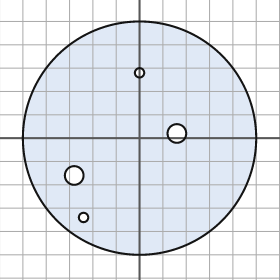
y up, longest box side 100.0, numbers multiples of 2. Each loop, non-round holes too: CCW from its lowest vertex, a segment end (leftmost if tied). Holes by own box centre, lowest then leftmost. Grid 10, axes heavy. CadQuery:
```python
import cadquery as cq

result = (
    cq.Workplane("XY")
    .moveTo(0.0, 0.0)
    .circle(50.0)
    .moveTo(-24.0, -34.0)
    .circle(2.0)
    .moveTo(-28.0, -16.0)
    .circle(4.0)
    .moveTo(16.0, 2.0)
    .circle(4.0)
    .moveTo(0.0, 28.0)
    .circle(2.0)
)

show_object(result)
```